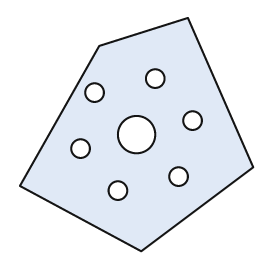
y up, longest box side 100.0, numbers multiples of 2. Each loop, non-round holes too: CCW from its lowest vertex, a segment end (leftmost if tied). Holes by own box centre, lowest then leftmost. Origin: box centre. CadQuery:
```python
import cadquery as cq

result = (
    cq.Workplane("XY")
    .moveTo(2.0, -50.0)
    .lineTo(50.0, -14.0)
    .lineTo(22.0, 50.0)
    .lineTo(-16.0, 38.0)
    .lineTo(-50.0, -22.0)
    .close()
    .moveTo(-8.0, -24.0)
    .circle(4.0)
    .moveTo(18.0, -18.0)
    .circle(4.0)
    .moveTo(-24.0, -6.0)
    .circle(4.0)
    .moveTo(0.0, 0.0)
    .circle(8.0)
    .moveTo(24.0, 6.0)
    .circle(4.0)
    .moveTo(-18.0, 18.0)
    .circle(4.0)
    .moveTo(8.0, 24.0)
    .circle(4.0)
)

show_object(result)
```